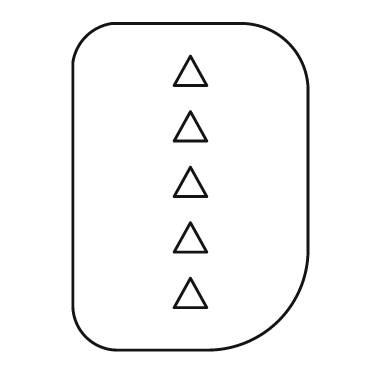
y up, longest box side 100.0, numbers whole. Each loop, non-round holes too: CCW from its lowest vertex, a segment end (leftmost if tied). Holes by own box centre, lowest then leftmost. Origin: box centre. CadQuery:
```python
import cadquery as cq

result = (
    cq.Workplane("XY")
    .moveTo(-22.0, -50.0)
    .lineTo(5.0, -50.0)
    .threePointArc((27.0, -41.0), (36.0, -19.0))
    .lineTo(36.0, 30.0)
    .threePointArc((30.0, 44.0), (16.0, 50.0))
    .lineTo(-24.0, 50.0)
    .threePointArc((-32.0, 46.0), (-36.0, 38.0))
    .lineTo(-36.0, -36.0)
    .threePointArc((-32.0, -46.0), (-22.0, -50.0))
    .close()
    .moveTo(-5.0, -37.0)
    .lineTo(5.0, -37.0)
    .lineTo(0.0, -28.0)
    .close()
    .moveTo(-5.0, -20.0)
    .lineTo(5.0, -20.0)
    .lineTo(0.0, -11.0)
    .close()
    .moveTo(-5.0, -3.0)
    .lineTo(5.0, -3.0)
    .lineTo(0.0, 6.0)
    .close()
    .moveTo(-5.0, 14.0)
    .lineTo(5.0, 14.0)
    .lineTo(0.0, 23.0)
    .close()
    .moveTo(-5.0, 31.0)
    .lineTo(5.0, 31.0)
    .lineTo(0.0, 40.0)
    .close()
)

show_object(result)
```